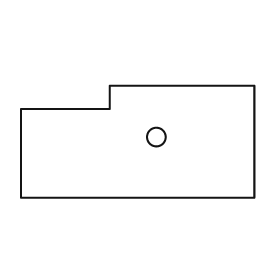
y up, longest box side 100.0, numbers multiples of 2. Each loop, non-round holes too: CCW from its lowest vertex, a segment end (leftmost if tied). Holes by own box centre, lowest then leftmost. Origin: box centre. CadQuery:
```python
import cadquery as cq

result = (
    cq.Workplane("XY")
    .moveTo(-50.0, -24.0)
    .lineTo(50.0, -24.0)
    .lineTo(50.0, 24.0)
    .lineTo(-12.0, 24.0)
    .lineTo(-12.0, 14.0)
    .lineTo(-50.0, 14.0)
    .close()
    .moveTo(8.0, 2.0)
    .circle(4.0)
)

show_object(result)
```